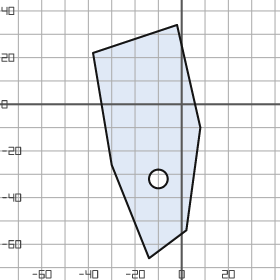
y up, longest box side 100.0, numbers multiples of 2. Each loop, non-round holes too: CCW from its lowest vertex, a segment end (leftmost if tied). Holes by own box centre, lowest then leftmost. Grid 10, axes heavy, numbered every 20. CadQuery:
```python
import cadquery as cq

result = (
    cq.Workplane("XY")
    .moveTo(-14.0, -66.0)
    .lineTo(2.0, -54.0)
    .lineTo(8.0, -10.0)
    .lineTo(-2.0, 34.0)
    .lineTo(-38.0, 22.0)
    .lineTo(-30.0, -26.0)
    .close()
    .moveTo(-10.0, -32.0)
    .circle(4.0)
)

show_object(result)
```